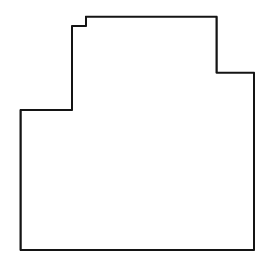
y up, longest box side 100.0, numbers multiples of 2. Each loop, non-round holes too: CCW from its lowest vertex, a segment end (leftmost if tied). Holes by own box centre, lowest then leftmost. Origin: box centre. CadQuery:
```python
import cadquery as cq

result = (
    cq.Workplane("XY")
    .moveTo(-50.0, -50.0)
    .lineTo(50.0, -50.0)
    .lineTo(50.0, 26.0)
    .lineTo(34.0, 26.0)
    .lineTo(34.0, 50.0)
    .lineTo(-22.0, 50.0)
    .lineTo(-22.0, 46.0)
    .lineTo(-28.0, 46.0)
    .lineTo(-28.0, 10.0)
    .lineTo(-50.0, 10.0)
    .close()
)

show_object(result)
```